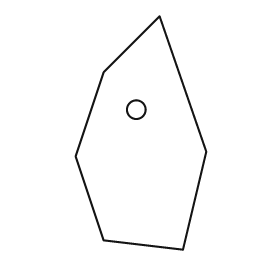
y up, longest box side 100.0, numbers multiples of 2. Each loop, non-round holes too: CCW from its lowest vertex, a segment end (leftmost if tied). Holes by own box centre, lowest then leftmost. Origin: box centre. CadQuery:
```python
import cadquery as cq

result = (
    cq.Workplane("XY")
    .moveTo(18.0, -50.0)
    .lineTo(28.0, -8.0)
    .lineTo(8.0, 50.0)
    .lineTo(-16.0, 26.0)
    .lineTo(-28.0, -10.0)
    .lineTo(-16.0, -46.0)
    .close()
    .moveTo(-2.0, 10.0)
    .circle(4.0)
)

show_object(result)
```